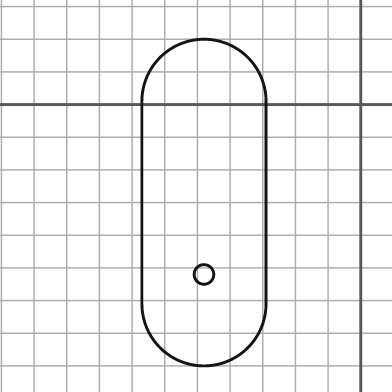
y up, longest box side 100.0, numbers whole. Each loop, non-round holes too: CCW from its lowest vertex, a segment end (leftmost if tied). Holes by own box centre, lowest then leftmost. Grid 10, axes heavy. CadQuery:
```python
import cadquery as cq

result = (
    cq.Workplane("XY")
    .moveTo(-67.0, -61.0)
    .threePointArc((-48.0, -80.0), (-29.0, -61.0))
    .lineTo(-29.0, 1.0)
    .threePointArc((-48.0, 20.0), (-67.0, 1.0))
    .close()
    .moveTo(-48.0, -52.0)
    .circle(3.0)
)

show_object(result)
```